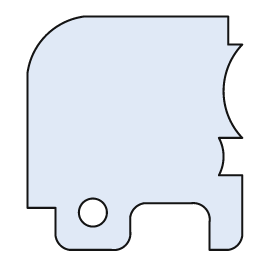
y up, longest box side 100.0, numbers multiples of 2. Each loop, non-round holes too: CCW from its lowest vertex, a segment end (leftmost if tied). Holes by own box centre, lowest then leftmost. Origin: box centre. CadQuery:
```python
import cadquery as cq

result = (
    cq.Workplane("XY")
    .moveTo(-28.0, -50.0)
    .lineTo(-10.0, -50.0)
    .threePointArc((-4.0, -48.0), (-2.0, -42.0))
    .lineTo(-2.0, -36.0)
    .threePointArc((0.0, -32.0), (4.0, -30.0))
    .lineTo(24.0, -30.0)
    .threePointArc((30.0, -32.0), (32.0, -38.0))
    .lineTo(32.0, -50.0)
    .lineTo(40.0, -50.0)
    .threePointArc((44.0, -48.0), (46.0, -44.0))
    .lineTo(46.0, -18.0)
    .lineTo(36.0, -18.0)
    .threePointArc((38.0, -10.0), (36.0, -2.0))
    .lineTo(46.0, -2.0)
    .threePointArc((38.0, 18.0), (46.0, 38.0))
    .lineTo(40.0, 38.0)
    .lineTo(40.0, 50.0)
    .lineTo(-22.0, 50.0)
    .threePointArc((-38.0, 42.0), (-46.0, 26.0))
    .lineTo(-46.0, -32.0)
    .lineTo(-34.0, -32.0)
    .lineTo(-34.0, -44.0)
    .threePointArc((-32.0, -48.0), (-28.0, -50.0))
    .close()
    .moveTo(-18.0, -34.0)
    .circle(6.0)
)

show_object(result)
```